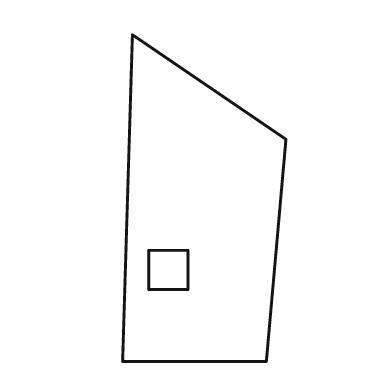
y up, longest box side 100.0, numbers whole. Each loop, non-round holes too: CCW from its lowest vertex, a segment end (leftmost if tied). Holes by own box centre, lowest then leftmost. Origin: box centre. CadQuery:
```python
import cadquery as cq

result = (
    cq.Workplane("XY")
    .moveTo(-25.0, -50.0)
    .lineTo(19.0, -50.0)
    .lineTo(25.0, 18.0)
    .lineTo(-22.0, 50.0)
    .close()
    .moveTo(-17.0, -28.0)
    .lineTo(-5.0, -28.0)
    .lineTo(-5.0, -16.0)
    .lineTo(-17.0, -16.0)
    .close()
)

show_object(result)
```